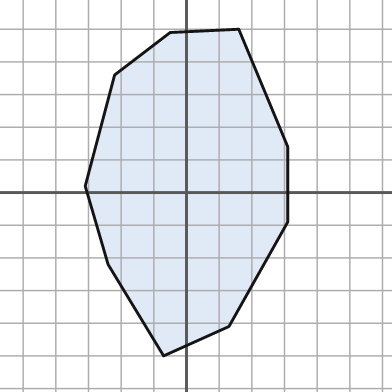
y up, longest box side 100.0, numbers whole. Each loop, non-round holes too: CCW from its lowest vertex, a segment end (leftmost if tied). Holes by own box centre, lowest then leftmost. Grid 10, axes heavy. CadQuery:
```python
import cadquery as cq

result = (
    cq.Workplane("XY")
    .moveTo(-7.0, -50.0)
    .lineTo(13.0, -41.0)
    .lineTo(31.0, -9.0)
    .lineTo(31.0, 14.0)
    .lineTo(16.0, 50.0)
    .lineTo(-5.0, 49.0)
    .lineTo(-22.0, 36.0)
    .lineTo(-31.0, 2.0)
    .lineTo(-24.0, -22.0)
    .close()
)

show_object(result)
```